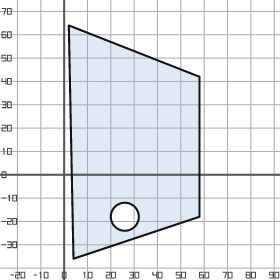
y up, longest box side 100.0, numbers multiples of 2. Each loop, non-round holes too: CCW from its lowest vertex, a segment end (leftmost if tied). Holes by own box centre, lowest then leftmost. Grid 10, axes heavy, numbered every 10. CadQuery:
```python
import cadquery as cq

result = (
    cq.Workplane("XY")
    .moveTo(4.0, -36.0)
    .lineTo(58.0, -18.0)
    .lineTo(58.0, 42.0)
    .lineTo(2.0, 64.0)
    .close()
    .moveTo(26.0, -18.0)
    .circle(6.0)
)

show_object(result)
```